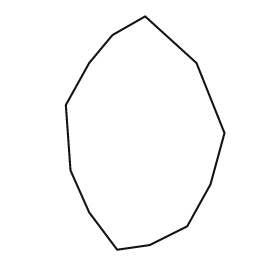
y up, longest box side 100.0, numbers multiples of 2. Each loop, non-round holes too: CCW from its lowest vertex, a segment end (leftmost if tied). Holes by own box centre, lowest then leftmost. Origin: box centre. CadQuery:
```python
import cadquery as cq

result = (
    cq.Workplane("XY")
    .moveTo(-12.0, -50.0)
    .lineTo(2.0, -48.0)
    .lineTo(18.0, -40.0)
    .lineTo(28.0, -22.0)
    .lineTo(34.0, 0.0)
    .lineTo(22.0, 30.0)
    .lineTo(0.0, 50.0)
    .lineTo(-14.0, 42.0)
    .lineTo(-24.0, 30.0)
    .lineTo(-34.0, 12.0)
    .lineTo(-32.0, -16.0)
    .lineTo(-24.0, -34.0)
    .close()
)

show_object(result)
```